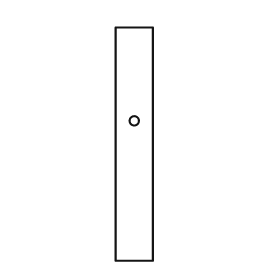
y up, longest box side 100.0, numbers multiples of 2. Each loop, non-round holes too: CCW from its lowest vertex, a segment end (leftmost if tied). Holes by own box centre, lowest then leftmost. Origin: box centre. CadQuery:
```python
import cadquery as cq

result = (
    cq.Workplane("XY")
    .moveTo(-8.0, -50.0)
    .lineTo(8.0, -50.0)
    .lineTo(8.0, 50.0)
    .lineTo(-8.0, 50.0)
    .close()
    .moveTo(0.0, 10.0)
    .circle(2.0)
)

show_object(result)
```